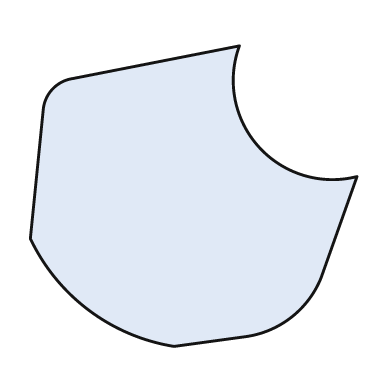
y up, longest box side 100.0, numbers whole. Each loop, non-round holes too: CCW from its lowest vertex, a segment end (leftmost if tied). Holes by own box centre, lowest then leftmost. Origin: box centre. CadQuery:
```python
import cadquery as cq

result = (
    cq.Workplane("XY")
    .moveTo(-6.0, -46.0)
    .lineTo(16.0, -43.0)
    .threePointArc((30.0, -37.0), (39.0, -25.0))
    .lineTo(50.0, 6.0)
    .threePointArc((20.0, 15.0), (14.0, 46.0))
    .lineTo(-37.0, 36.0)
    .threePointArc((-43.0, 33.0), (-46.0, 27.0))
    .lineTo(-50.0, -13.0)
    .threePointArc((-32.0, -35.0), (-6.0, -46.0))
    .close()
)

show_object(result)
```